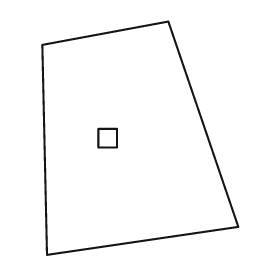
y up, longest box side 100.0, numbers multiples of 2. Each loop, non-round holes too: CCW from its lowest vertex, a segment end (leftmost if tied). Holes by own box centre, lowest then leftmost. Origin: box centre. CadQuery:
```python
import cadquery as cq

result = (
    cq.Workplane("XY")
    .moveTo(-40.0, -50.0)
    .lineTo(42.0, -38.0)
    .lineTo(12.0, 50.0)
    .lineTo(-42.0, 40.0)
    .close()
    .moveTo(-18.0, -4.0)
    .lineTo(-10.0, -4.0)
    .lineTo(-10.0, 4.0)
    .lineTo(-18.0, 4.0)
    .close()
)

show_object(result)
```